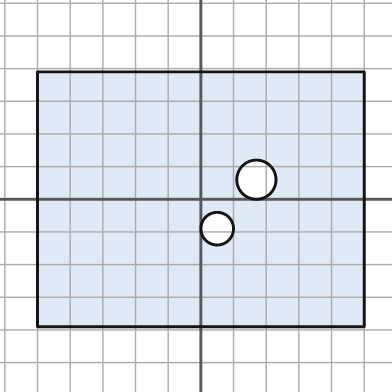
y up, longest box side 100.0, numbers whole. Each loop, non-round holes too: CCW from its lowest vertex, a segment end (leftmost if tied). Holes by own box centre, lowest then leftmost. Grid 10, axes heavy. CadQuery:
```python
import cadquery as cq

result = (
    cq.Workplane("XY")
    .moveTo(-50.0, -39.0)
    .lineTo(50.0, -39.0)
    .lineTo(50.0, 39.0)
    .lineTo(-50.0, 39.0)
    .close()
    .moveTo(5.0, -9.0)
    .circle(5.0)
    .moveTo(17.0, 6.0)
    .circle(6.0)
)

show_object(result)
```